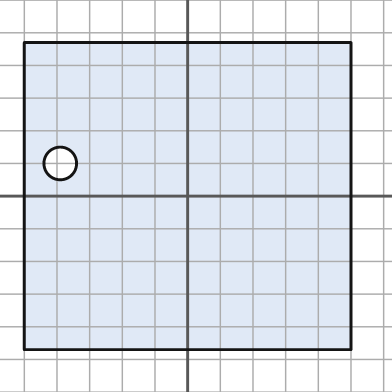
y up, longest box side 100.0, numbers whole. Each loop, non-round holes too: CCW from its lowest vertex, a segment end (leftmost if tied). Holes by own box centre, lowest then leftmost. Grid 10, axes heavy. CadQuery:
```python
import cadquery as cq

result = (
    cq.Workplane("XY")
    .moveTo(-50.0, -47.0)
    .lineTo(50.0, -47.0)
    .lineTo(50.0, 47.0)
    .lineTo(-50.0, 47.0)
    .close()
    .moveTo(-39.0, 10.0)
    .circle(5.0)
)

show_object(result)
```